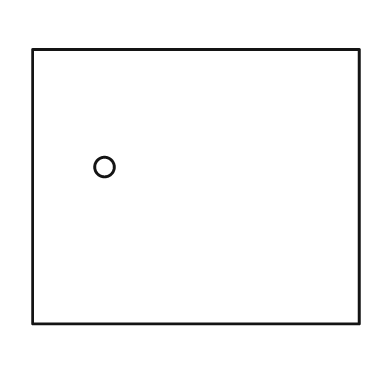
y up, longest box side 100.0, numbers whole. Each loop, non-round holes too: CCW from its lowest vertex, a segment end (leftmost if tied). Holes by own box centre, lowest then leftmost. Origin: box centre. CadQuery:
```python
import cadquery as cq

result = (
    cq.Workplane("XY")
    .moveTo(-50.0, -42.0)
    .lineTo(50.0, -42.0)
    .lineTo(50.0, 42.0)
    .lineTo(-50.0, 42.0)
    .close()
    .moveTo(-28.0, 6.0)
    .circle(3.0)
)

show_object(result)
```